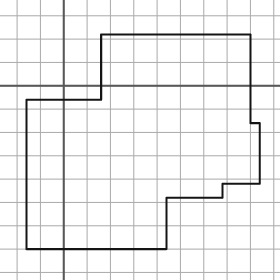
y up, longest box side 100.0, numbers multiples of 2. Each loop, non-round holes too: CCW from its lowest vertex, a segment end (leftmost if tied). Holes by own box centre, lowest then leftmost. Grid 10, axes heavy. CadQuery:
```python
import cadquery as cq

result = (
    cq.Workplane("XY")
    .moveTo(-16.0, -70.0)
    .lineTo(44.0, -70.0)
    .lineTo(44.0, -48.0)
    .lineTo(68.0, -48.0)
    .lineTo(68.0, -42.0)
    .lineTo(84.0, -42.0)
    .lineTo(84.0, -16.0)
    .lineTo(80.0, -16.0)
    .lineTo(80.0, 22.0)
    .lineTo(16.0, 22.0)
    .lineTo(16.0, -6.0)
    .lineTo(-16.0, -6.0)
    .close()
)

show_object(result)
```